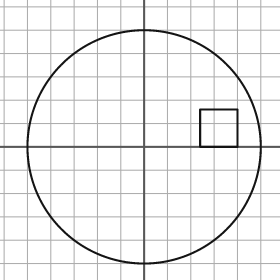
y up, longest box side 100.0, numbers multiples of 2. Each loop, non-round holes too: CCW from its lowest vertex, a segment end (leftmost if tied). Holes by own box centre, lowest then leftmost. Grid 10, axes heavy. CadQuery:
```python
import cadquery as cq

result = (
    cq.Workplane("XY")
    .moveTo(0.0, 0.0)
    .circle(50.0)
    .moveTo(24.0, 0.0)
    .lineTo(40.0, 0.0)
    .lineTo(40.0, 16.0)
    .lineTo(24.0, 16.0)
    .close()
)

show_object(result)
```